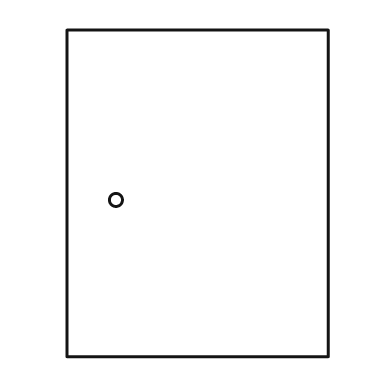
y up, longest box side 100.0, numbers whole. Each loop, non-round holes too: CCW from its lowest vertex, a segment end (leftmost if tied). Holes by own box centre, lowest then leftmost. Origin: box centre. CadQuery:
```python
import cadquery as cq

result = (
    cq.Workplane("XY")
    .moveTo(-40.0, -50.0)
    .lineTo(40.0, -50.0)
    .lineTo(40.0, 50.0)
    .lineTo(-40.0, 50.0)
    .close()
    .moveTo(-25.0, -2.0)
    .circle(2.0)
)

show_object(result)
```